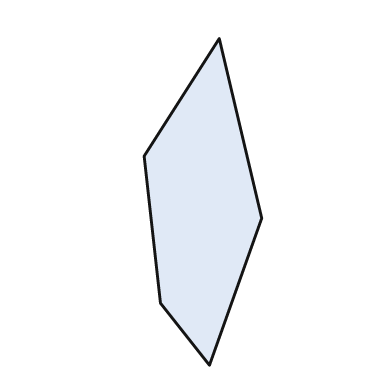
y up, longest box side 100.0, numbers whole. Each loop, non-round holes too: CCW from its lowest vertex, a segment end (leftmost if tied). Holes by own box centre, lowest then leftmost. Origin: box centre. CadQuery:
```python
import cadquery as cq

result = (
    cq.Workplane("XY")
    .moveTo(2.0, -50.0)
    .lineTo(18.0, -5.0)
    .lineTo(5.0, 50.0)
    .lineTo(-18.0, 14.0)
    .lineTo(-13.0, -31.0)
    .close()
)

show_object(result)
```